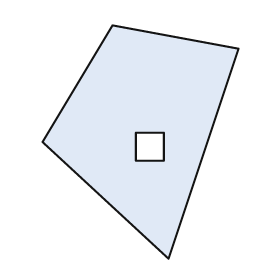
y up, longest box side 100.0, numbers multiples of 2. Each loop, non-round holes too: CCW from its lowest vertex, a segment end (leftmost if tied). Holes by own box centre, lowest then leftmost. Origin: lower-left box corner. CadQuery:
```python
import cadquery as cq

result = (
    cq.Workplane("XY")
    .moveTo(54.0, 0.0)
    .lineTo(84.0, 90.0)
    .lineTo(30.0, 100.0)
    .lineTo(0.0, 50.0)
    .close()
    .moveTo(40.0, 42.0)
    .lineTo(52.0, 42.0)
    .lineTo(52.0, 54.0)
    .lineTo(40.0, 54.0)
    .close()
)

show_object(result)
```